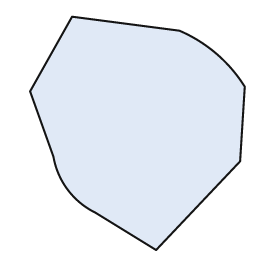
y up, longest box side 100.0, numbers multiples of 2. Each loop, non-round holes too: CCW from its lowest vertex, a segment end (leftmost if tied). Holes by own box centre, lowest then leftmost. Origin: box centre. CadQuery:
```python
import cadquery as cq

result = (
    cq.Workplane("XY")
    .moveTo(8.0, -50.0)
    .lineTo(44.0, -12.0)
    .lineTo(46.0, 20.0)
    .threePointArc((34.0, 34.0), (18.0, 44.0))
    .lineTo(-28.0, 50.0)
    .lineTo(-46.0, 18.0)
    .lineTo(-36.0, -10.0)
    .threePointArc((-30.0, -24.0), (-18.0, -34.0))
    .close()
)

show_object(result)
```